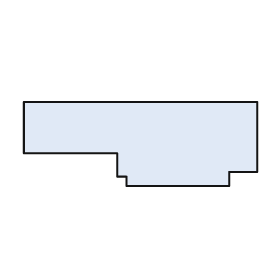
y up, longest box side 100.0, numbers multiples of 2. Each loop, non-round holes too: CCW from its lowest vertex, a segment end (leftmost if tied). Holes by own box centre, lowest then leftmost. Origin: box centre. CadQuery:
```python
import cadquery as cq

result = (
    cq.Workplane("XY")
    .moveTo(-6.0, -18.0)
    .lineTo(38.0, -18.0)
    .lineTo(38.0, -12.0)
    .lineTo(50.0, -12.0)
    .lineTo(50.0, 18.0)
    .lineTo(-50.0, 18.0)
    .lineTo(-50.0, -4.0)
    .lineTo(-10.0, -4.0)
    .lineTo(-10.0, -14.0)
    .lineTo(-6.0, -14.0)
    .close()
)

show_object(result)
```